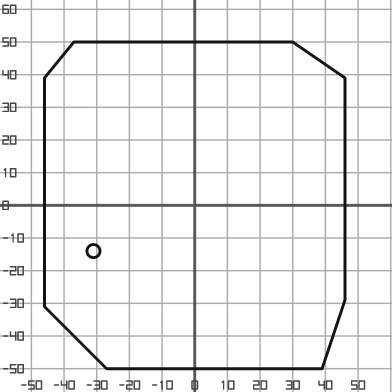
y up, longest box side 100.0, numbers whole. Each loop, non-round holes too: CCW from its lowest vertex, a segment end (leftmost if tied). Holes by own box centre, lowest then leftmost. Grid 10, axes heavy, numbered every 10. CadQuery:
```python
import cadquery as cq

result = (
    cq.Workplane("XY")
    .moveTo(-27.0, -50.0)
    .lineTo(39.0, -50.0)
    .lineTo(46.0, -29.0)
    .lineTo(46.0, 39.0)
    .lineTo(30.0, 50.0)
    .lineTo(-37.0, 50.0)
    .lineTo(-46.0, 39.0)
    .lineTo(-46.0, -31.0)
    .close()
    .moveTo(-31.0, -14.0)
    .circle(2.0)
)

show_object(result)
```